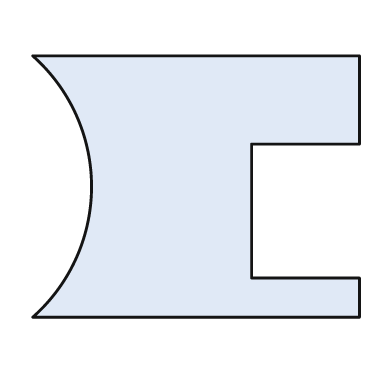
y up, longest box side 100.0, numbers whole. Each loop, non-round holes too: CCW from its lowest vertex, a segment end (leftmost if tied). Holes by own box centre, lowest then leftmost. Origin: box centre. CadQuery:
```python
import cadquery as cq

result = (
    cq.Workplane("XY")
    .moveTo(-50.0, -40.0)
    .lineTo(50.0, -40.0)
    .lineTo(50.0, -28.0)
    .lineTo(17.0, -28.0)
    .lineTo(17.0, 13.0)
    .lineTo(50.0, 13.0)
    .lineTo(50.0, 40.0)
    .lineTo(-50.0, 40.0)
    .threePointArc((-32.0, 0.0), (-50.0, -40.0))
    .close()
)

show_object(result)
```